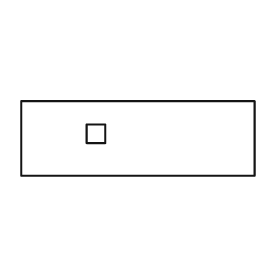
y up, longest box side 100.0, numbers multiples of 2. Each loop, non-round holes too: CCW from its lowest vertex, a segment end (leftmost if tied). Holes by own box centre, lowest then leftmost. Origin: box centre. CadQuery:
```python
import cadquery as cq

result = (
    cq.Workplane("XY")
    .moveTo(-50.0, -16.0)
    .lineTo(50.0, -16.0)
    .lineTo(50.0, 16.0)
    .lineTo(-50.0, 16.0)
    .close()
    .moveTo(-22.0, -2.0)
    .lineTo(-14.0, -2.0)
    .lineTo(-14.0, 6.0)
    .lineTo(-22.0, 6.0)
    .close()
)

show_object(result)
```